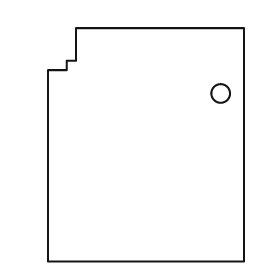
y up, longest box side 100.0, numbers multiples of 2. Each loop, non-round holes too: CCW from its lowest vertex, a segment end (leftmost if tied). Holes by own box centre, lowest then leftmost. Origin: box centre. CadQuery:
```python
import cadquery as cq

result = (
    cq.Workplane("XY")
    .moveTo(-42.0, -50.0)
    .lineTo(42.0, -50.0)
    .lineTo(42.0, 50.0)
    .lineTo(-30.0, 50.0)
    .lineTo(-30.0, 36.0)
    .lineTo(-34.0, 36.0)
    .lineTo(-34.0, 32.0)
    .lineTo(-42.0, 32.0)
    .close()
    .moveTo(32.0, 22.0)
    .circle(4.0)
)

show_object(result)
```